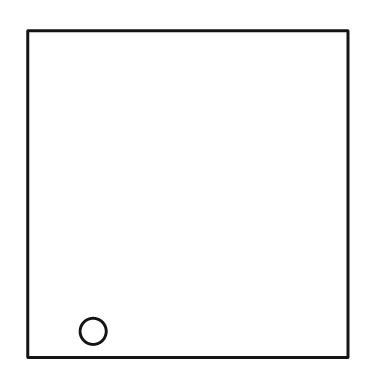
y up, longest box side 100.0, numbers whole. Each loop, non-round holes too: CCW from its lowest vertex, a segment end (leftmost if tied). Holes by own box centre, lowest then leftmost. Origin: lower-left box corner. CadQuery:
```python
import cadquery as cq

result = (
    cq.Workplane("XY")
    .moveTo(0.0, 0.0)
    .lineTo(98.0, 0.0)
    .lineTo(98.0, 100.0)
    .lineTo(0.0, 100.0)
    .close()
    .moveTo(20.0, 8.0)
    .circle(4.0)
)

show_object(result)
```